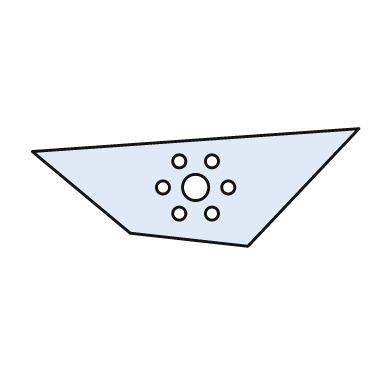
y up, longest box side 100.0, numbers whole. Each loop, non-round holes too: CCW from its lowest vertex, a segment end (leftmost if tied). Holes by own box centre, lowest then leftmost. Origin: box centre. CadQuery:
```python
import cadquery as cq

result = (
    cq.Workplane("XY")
    .moveTo(16.0, -18.0)
    .lineTo(50.0, 18.0)
    .lineTo(-50.0, 11.0)
    .lineTo(-20.0, -14.0)
    .close()
    .moveTo(-5.0, -8.0)
    .circle(2.0)
    .moveTo(5.0, -8.0)
    .circle(2.0)
    .moveTo(-10.0, 0.0)
    .circle(2.0)
    .moveTo(0.0, 0.0)
    .circle(4.0)
    .moveTo(10.0, 0.0)
    .circle(2.0)
    .moveTo(-5.0, 8.0)
    .circle(2.0)
    .moveTo(5.0, 8.0)
    .circle(2.0)
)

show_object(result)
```